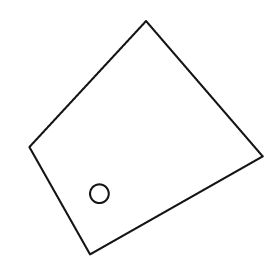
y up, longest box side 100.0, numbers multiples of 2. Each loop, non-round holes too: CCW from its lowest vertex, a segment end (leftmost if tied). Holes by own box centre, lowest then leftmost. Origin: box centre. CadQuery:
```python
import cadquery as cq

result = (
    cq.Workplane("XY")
    .moveTo(-24.0, -50.0)
    .lineTo(50.0, -8.0)
    .lineTo(0.0, 50.0)
    .lineTo(-50.0, -4.0)
    .close()
    .moveTo(-20.0, -24.0)
    .circle(4.0)
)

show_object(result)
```